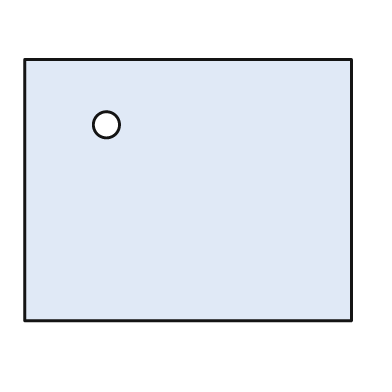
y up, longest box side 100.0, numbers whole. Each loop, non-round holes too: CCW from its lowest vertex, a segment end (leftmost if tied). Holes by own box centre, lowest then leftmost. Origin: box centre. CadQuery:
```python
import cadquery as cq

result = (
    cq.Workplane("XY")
    .moveTo(-50.0, -40.0)
    .lineTo(50.0, -40.0)
    .lineTo(50.0, 40.0)
    .lineTo(-50.0, 40.0)
    .close()
    .moveTo(-25.0, 20.0)
    .circle(4.0)
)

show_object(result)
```